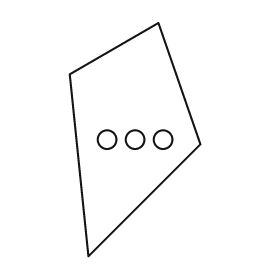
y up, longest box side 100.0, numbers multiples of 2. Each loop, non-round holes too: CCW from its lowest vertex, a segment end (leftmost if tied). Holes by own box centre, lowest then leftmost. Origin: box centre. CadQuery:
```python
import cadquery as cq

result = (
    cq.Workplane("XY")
    .moveTo(-20.0, -50.0)
    .lineTo(28.0, -2.0)
    .lineTo(10.0, 50.0)
    .lineTo(-28.0, 28.0)
    .close()
    .moveTo(-12.0, 0.0)
    .circle(4.0)
    .moveTo(0.0, 0.0)
    .circle(4.0)
    .moveTo(12.0, 0.0)
    .circle(4.0)
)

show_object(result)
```